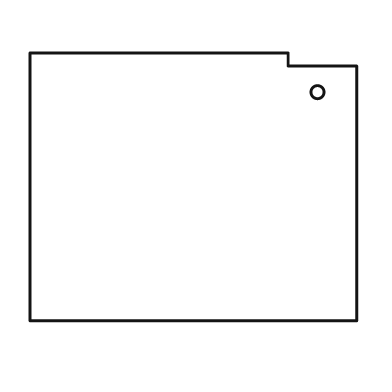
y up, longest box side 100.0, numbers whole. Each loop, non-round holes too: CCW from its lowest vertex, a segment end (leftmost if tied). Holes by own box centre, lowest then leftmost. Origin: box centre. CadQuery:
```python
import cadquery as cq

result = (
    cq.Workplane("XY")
    .moveTo(-50.0, -41.0)
    .lineTo(50.0, -41.0)
    .lineTo(50.0, 37.0)
    .lineTo(29.0, 37.0)
    .lineTo(29.0, 41.0)
    .lineTo(-50.0, 41.0)
    .close()
    .moveTo(38.0, 29.0)
    .circle(2.0)
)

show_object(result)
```